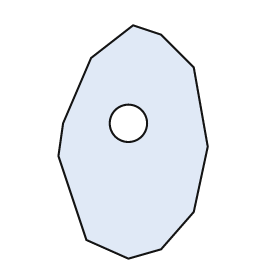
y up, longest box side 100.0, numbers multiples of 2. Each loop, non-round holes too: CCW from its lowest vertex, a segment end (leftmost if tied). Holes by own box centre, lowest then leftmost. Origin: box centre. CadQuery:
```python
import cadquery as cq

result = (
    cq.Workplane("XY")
    .moveTo(-2.0, -50.0)
    .lineTo(12.0, -46.0)
    .lineTo(26.0, -30.0)
    .lineTo(32.0, -2.0)
    .lineTo(26.0, 32.0)
    .lineTo(12.0, 46.0)
    .lineTo(0.0, 50.0)
    .lineTo(-18.0, 36.0)
    .lineTo(-30.0, 8.0)
    .lineTo(-32.0, -6.0)
    .lineTo(-20.0, -42.0)
    .close()
    .moveTo(-2.0, 8.0)
    .circle(8.0)
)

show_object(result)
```